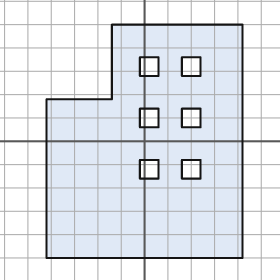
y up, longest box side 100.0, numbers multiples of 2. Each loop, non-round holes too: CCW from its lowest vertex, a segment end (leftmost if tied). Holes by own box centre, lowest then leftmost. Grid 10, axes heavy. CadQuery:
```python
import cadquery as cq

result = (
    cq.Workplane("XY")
    .moveTo(-42.0, -50.0)
    .lineTo(42.0, -50.0)
    .lineTo(42.0, 50.0)
    .lineTo(-14.0, 50.0)
    .lineTo(-14.0, 18.0)
    .lineTo(-42.0, 18.0)
    .close()
    .moveTo(-2.0, -16.0)
    .lineTo(6.0, -16.0)
    .lineTo(6.0, -8.0)
    .lineTo(-2.0, -8.0)
    .close()
    .moveTo(16.0, -16.0)
    .lineTo(24.0, -16.0)
    .lineTo(24.0, -8.0)
    .lineTo(16.0, -8.0)
    .close()
    .moveTo(-2.0, 6.0)
    .lineTo(6.0, 6.0)
    .lineTo(6.0, 14.0)
    .lineTo(-2.0, 14.0)
    .close()
    .moveTo(16.0, 6.0)
    .lineTo(24.0, 6.0)
    .lineTo(24.0, 14.0)
    .lineTo(16.0, 14.0)
    .close()
    .moveTo(-2.0, 28.0)
    .lineTo(6.0, 28.0)
    .lineTo(6.0, 36.0)
    .lineTo(-2.0, 36.0)
    .close()
    .moveTo(16.0, 28.0)
    .lineTo(24.0, 28.0)
    .lineTo(24.0, 36.0)
    .lineTo(16.0, 36.0)
    .close()
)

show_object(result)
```